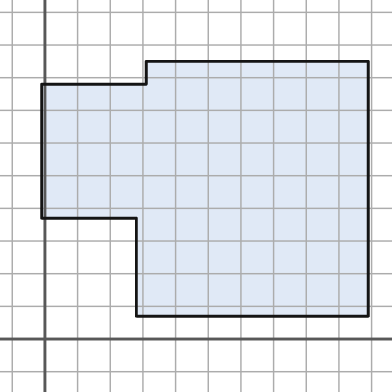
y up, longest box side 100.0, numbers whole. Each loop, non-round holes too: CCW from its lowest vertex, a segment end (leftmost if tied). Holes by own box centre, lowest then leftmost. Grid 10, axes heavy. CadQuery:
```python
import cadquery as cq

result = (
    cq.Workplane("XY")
    .moveTo(28.0, 7.0)
    .lineTo(99.0, 7.0)
    .lineTo(99.0, 85.0)
    .lineTo(31.0, 85.0)
    .lineTo(31.0, 78.0)
    .lineTo(-1.0, 78.0)
    .lineTo(-1.0, 37.0)
    .lineTo(28.0, 37.0)
    .close()
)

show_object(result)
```